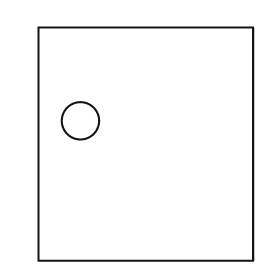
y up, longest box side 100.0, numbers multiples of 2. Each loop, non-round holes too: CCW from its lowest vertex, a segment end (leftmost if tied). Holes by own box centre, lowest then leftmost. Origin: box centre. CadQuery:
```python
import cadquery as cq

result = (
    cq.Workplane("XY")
    .moveTo(-46.0, -50.0)
    .lineTo(46.0, -50.0)
    .lineTo(46.0, 50.0)
    .lineTo(-46.0, 50.0)
    .close()
    .moveTo(-28.0, 10.0)
    .circle(8.0)
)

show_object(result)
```